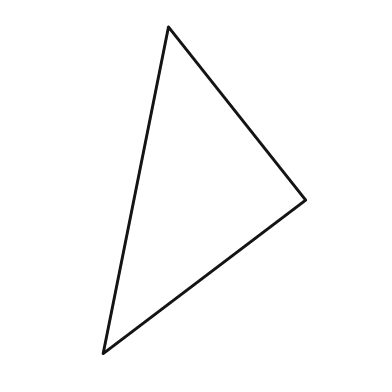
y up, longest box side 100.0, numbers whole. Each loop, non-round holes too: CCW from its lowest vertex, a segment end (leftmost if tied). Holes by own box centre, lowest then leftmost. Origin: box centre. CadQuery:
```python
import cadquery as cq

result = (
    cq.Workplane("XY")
    .moveTo(-31.0, -50.0)
    .lineTo(31.0, -3.0)
    .lineTo(-11.0, 50.0)
    .close()
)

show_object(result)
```